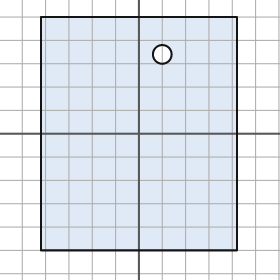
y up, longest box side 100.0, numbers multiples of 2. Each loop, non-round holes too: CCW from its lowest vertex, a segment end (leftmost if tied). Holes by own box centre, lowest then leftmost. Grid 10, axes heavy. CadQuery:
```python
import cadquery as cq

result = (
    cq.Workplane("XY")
    .moveTo(-42.0, -50.0)
    .lineTo(42.0, -50.0)
    .lineTo(42.0, 50.0)
    .lineTo(-42.0, 50.0)
    .close()
    .moveTo(10.0, 34.0)
    .circle(4.0)
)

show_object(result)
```